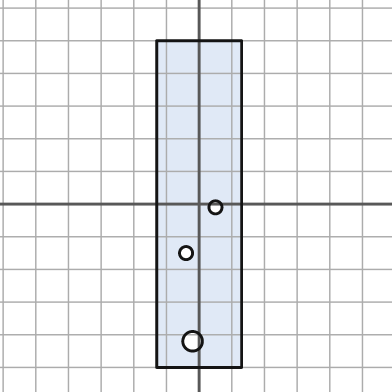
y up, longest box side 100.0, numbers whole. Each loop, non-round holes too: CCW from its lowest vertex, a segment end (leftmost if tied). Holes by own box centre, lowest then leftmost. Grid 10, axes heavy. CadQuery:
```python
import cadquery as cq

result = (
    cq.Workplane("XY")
    .moveTo(-13.0, -50.0)
    .lineTo(13.0, -50.0)
    .lineTo(13.0, 50.0)
    .lineTo(-13.0, 50.0)
    .close()
    .moveTo(-2.0, -42.0)
    .circle(3.0)
    .moveTo(-4.0, -15.0)
    .circle(2.0)
    .moveTo(5.0, -1.0)
    .circle(2.0)
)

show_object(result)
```